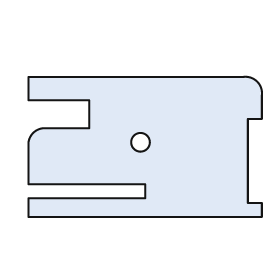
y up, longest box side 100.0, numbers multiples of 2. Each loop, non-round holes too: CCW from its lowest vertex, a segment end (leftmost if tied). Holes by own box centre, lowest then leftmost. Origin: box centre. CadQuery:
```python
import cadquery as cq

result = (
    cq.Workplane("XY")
    .moveTo(-50.0, -30.0)
    .lineTo(50.0, -30.0)
    .lineTo(50.0, -24.0)
    .lineTo(44.0, -24.0)
    .lineTo(44.0, 12.0)
    .lineTo(50.0, 12.0)
    .lineTo(50.0, 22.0)
    .threePointArc((48.0, 28.0), (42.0, 30.0))
    .lineTo(-50.0, 30.0)
    .lineTo(-50.0, 20.0)
    .lineTo(-24.0, 20.0)
    .lineTo(-24.0, 8.0)
    .lineTo(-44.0, 8.0)
    .threePointArc((-48.0, 6.0), (-50.0, 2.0))
    .lineTo(-50.0, -16.0)
    .lineTo(0.0, -16.0)
    .lineTo(0.0, -22.0)
    .lineTo(-50.0, -22.0)
    .close()
    .moveTo(-2.0, 2.0)
    .circle(4.0)
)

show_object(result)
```